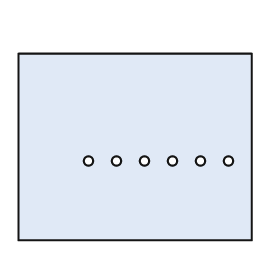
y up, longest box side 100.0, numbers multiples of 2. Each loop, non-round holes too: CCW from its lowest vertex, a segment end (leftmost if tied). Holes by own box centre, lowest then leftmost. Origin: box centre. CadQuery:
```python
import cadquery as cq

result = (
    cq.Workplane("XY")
    .moveTo(-50.0, -40.0)
    .lineTo(50.0, -40.0)
    .lineTo(50.0, 40.0)
    .lineTo(-50.0, 40.0)
    .close()
    .moveTo(-20.0, -6.0)
    .circle(2.0)
    .moveTo(-8.0, -6.0)
    .circle(2.0)
    .moveTo(4.0, -6.0)
    .circle(2.0)
    .moveTo(16.0, -6.0)
    .circle(2.0)
    .moveTo(28.0, -6.0)
    .circle(2.0)
    .moveTo(40.0, -6.0)
    .circle(2.0)
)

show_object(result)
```